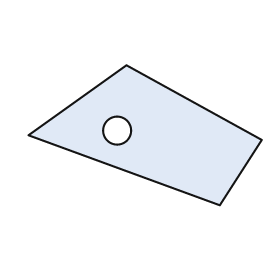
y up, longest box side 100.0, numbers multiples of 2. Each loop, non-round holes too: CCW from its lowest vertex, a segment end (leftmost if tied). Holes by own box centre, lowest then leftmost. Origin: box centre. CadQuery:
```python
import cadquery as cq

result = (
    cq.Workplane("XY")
    .moveTo(32.0, -30.0)
    .lineTo(50.0, -2.0)
    .lineTo(-8.0, 30.0)
    .lineTo(-50.0, 0.0)
    .close()
    .moveTo(-12.0, 2.0)
    .circle(6.0)
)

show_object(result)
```